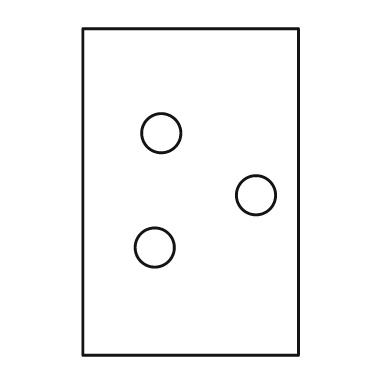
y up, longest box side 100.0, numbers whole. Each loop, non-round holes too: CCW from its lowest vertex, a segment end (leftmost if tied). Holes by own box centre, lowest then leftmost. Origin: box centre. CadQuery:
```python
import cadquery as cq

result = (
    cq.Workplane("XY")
    .moveTo(-33.0, -50.0)
    .lineTo(33.0, -50.0)
    .lineTo(33.0, 50.0)
    .lineTo(-33.0, 50.0)
    .close()
    .moveTo(-11.0, -17.0)
    .circle(6.0)
    .moveTo(20.0, -1.0)
    .circle(6.0)
    .moveTo(-9.0, 18.0)
    .circle(6.0)
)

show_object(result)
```